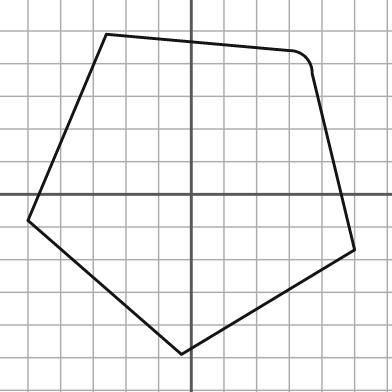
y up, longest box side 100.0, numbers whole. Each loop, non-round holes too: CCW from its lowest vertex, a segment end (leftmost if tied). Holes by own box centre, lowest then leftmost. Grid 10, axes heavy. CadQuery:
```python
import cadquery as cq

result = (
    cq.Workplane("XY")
    .moveTo(-3.0, -49.0)
    .lineTo(50.0, -17.0)
    .lineTo(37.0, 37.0)
    .threePointArc((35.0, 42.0), (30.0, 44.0))
    .lineTo(-26.0, 49.0)
    .lineTo(-50.0, -8.0)
    .close()
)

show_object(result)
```